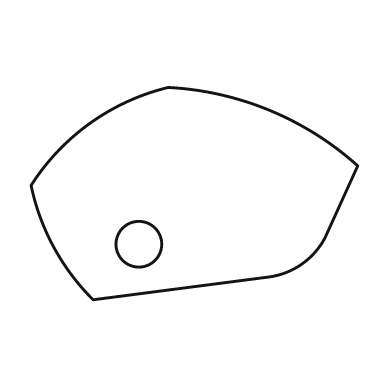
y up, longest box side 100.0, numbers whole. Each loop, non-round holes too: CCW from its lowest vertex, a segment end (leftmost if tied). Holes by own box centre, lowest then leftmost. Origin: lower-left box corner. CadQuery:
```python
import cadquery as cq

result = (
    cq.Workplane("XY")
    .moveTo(19.0, 0.0)
    .lineTo(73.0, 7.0)
    .threePointArc((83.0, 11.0), (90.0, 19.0))
    .lineTo(100.0, 41.0)
    .threePointArc((73.0, 58.0), (42.0, 65.0))
    .threePointArc((18.0, 54.0), (0.0, 35.0))
    .threePointArc((7.0, 16.0), (19.0, 0.0))
    .close()
    .moveTo(33.0, 17.0)
    .circle(7.0)
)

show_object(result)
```